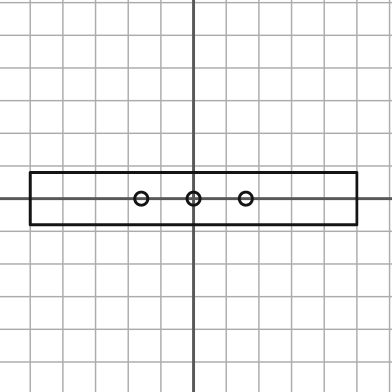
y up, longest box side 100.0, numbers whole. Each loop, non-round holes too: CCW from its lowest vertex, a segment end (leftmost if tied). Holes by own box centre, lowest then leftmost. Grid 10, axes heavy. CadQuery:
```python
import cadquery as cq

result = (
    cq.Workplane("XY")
    .moveTo(-50.0, -8.0)
    .lineTo(50.0, -8.0)
    .lineTo(50.0, 8.0)
    .lineTo(-50.0, 8.0)
    .close()
    .moveTo(-16.0, 0.0)
    .circle(2.0)
    .moveTo(0.0, 0.0)
    .circle(2.0)
    .moveTo(16.0, 0.0)
    .circle(2.0)
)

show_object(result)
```